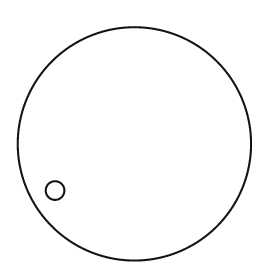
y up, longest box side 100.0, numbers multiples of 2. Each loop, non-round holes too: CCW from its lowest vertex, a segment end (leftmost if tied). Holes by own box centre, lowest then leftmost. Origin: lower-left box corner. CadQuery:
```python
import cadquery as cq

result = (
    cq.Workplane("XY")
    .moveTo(50.0, 50.0)
    .circle(50.0)
    .moveTo(16.0, 30.0)
    .circle(4.0)
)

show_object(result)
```